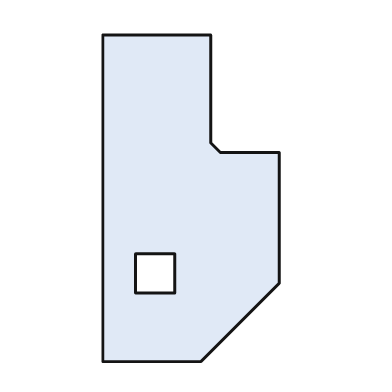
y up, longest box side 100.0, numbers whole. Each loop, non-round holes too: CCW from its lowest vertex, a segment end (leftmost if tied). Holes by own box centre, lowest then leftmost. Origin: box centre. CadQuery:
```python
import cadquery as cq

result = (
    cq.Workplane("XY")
    .moveTo(-27.0, -50.0)
    .lineTo(3.0, -50.0)
    .lineTo(27.0, -26.0)
    .lineTo(27.0, 14.0)
    .lineTo(9.0, 14.0)
    .lineTo(6.0, 17.0)
    .lineTo(6.0, 50.0)
    .lineTo(-27.0, 50.0)
    .close()
    .moveTo(-17.0, -29.0)
    .lineTo(-5.0, -29.0)
    .lineTo(-5.0, -17.0)
    .lineTo(-17.0, -17.0)
    .close()
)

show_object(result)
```